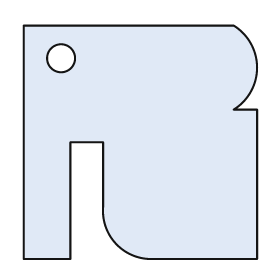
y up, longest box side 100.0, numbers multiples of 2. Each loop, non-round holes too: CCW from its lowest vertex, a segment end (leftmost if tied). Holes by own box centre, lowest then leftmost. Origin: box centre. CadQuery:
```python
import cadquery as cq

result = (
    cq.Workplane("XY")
    .moveTo(-50.0, -50.0)
    .lineTo(-30.0, -50.0)
    .lineTo(-30.0, 0.0)
    .lineTo(-16.0, 0.0)
    .lineTo(-16.0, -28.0)
    .threePointArc((-10.0, -44.0), (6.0, -50.0))
    .lineTo(50.0, -50.0)
    .lineTo(50.0, 14.0)
    .lineTo(40.0, 14.0)
    .threePointArc((50.0, 32.0), (40.0, 50.0))
    .lineTo(-50.0, 50.0)
    .close()
    .moveTo(-34.0, 36.0)
    .circle(6.0)
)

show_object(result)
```